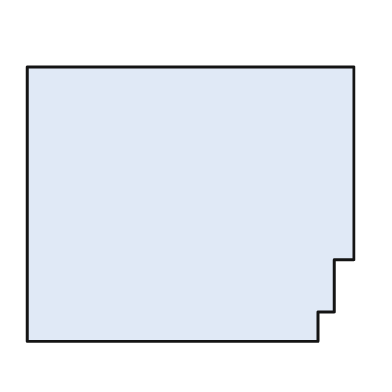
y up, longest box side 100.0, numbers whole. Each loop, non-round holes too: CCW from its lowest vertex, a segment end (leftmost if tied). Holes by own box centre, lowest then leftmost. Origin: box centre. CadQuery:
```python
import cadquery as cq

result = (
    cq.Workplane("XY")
    .moveTo(-50.0, -42.0)
    .lineTo(39.0, -42.0)
    .lineTo(39.0, -33.0)
    .lineTo(44.0, -33.0)
    .lineTo(44.0, -17.0)
    .lineTo(50.0, -17.0)
    .lineTo(50.0, 42.0)
    .lineTo(-50.0, 42.0)
    .close()
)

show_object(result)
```